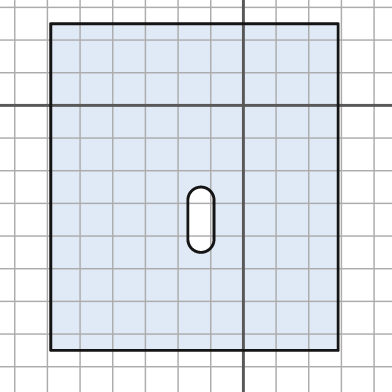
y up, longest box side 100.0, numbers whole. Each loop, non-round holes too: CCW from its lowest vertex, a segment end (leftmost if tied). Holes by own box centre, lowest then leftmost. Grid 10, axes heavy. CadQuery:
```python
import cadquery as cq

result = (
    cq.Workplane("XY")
    .moveTo(-59.0, -75.0)
    .lineTo(29.0, -75.0)
    .lineTo(29.0, 25.0)
    .lineTo(-59.0, 25.0)
    .close()
    .moveTo(-17.0, -41.0)
    .threePointArc((-13.0, -45.0), (-9.0, -41.0))
    .lineTo(-9.0, -29.0)
    .threePointArc((-13.0, -25.0), (-17.0, -29.0))
    .close()
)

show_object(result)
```